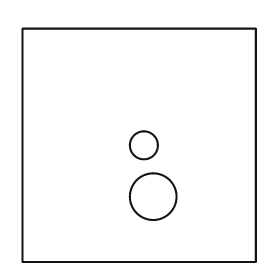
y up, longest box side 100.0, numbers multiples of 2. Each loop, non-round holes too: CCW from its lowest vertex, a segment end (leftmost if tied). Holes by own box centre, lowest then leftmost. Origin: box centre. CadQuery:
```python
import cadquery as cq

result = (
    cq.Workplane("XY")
    .moveTo(-50.0, -50.0)
    .lineTo(50.0, -50.0)
    .lineTo(50.0, 50.0)
    .lineTo(-50.0, 50.0)
    .close()
    .moveTo(6.0, -22.0)
    .circle(10.0)
    .moveTo(2.0, 0.0)
    .circle(6.0)
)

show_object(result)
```